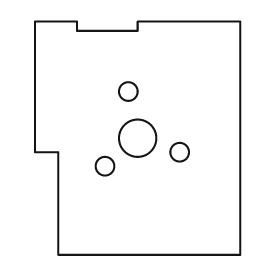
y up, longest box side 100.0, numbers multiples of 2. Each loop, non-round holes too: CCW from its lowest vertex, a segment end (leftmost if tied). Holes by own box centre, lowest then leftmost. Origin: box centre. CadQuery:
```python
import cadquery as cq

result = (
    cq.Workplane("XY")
    .moveTo(-34.0, -50.0)
    .lineTo(44.0, -50.0)
    .lineTo(44.0, 50.0)
    .lineTo(0.0, 50.0)
    .lineTo(0.0, 46.0)
    .lineTo(-26.0, 46.0)
    .lineTo(-26.0, 50.0)
    .lineTo(-44.0, 50.0)
    .lineTo(-44.0, -6.0)
    .lineTo(-34.0, -6.0)
    .close()
    .moveTo(-14.0, -12.0)
    .circle(4.0)
    .moveTo(18.0, -6.0)
    .circle(4.0)
    .moveTo(0.0, 0.0)
    .circle(8.0)
    .moveTo(-4.0, 20.0)
    .circle(4.0)
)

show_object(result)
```